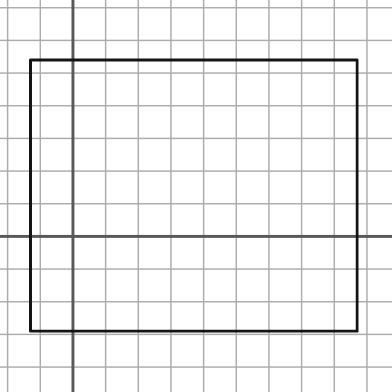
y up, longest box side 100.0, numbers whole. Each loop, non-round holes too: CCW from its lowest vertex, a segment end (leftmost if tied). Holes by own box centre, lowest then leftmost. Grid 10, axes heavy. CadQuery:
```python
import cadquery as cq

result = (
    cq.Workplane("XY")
    .moveTo(-13.0, -29.0)
    .lineTo(87.0, -29.0)
    .lineTo(87.0, 54.0)
    .lineTo(-13.0, 54.0)
    .close()
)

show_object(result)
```